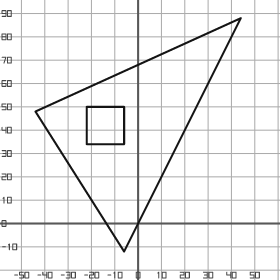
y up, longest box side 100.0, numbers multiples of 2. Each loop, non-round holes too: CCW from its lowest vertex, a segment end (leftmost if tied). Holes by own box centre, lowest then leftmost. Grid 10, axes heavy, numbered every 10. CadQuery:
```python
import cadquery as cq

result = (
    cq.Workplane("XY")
    .moveTo(-6.0, -12.0)
    .lineTo(44.0, 88.0)
    .lineTo(-44.0, 48.0)
    .close()
    .moveTo(-22.0, 34.0)
    .lineTo(-6.0, 34.0)
    .lineTo(-6.0, 50.0)
    .lineTo(-22.0, 50.0)
    .close()
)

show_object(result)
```